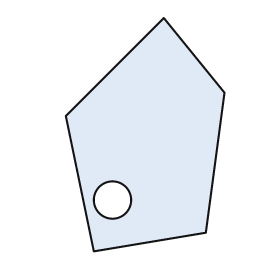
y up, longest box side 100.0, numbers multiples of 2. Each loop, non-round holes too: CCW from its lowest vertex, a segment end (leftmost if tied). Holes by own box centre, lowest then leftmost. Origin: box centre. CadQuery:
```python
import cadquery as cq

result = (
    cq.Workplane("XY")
    .moveTo(-22.0, -50.0)
    .lineTo(26.0, -42.0)
    .lineTo(34.0, 18.0)
    .lineTo(8.0, 50.0)
    .lineTo(-34.0, 8.0)
    .close()
    .moveTo(-14.0, -28.0)
    .circle(8.0)
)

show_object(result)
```